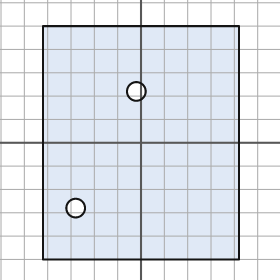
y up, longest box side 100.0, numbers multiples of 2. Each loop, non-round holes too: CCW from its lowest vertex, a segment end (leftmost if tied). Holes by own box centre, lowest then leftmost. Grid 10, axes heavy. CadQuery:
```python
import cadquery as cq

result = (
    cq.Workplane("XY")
    .moveTo(-42.0, -50.0)
    .lineTo(42.0, -50.0)
    .lineTo(42.0, 50.0)
    .lineTo(-42.0, 50.0)
    .close()
    .moveTo(-28.0, -28.0)
    .circle(4.0)
    .moveTo(-2.0, 22.0)
    .circle(4.0)
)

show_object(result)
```